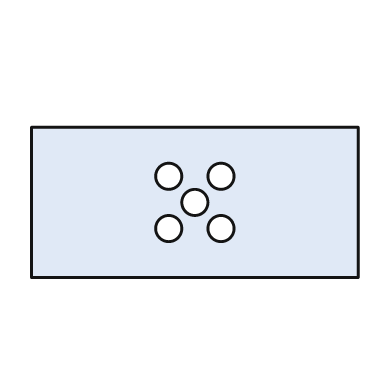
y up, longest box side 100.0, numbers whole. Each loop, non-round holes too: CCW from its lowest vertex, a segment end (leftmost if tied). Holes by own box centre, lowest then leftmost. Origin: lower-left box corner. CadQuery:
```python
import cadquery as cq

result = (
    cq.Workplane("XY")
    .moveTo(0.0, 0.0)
    .lineTo(100.0, 0.0)
    .lineTo(100.0, 46.0)
    .lineTo(0.0, 46.0)
    .close()
    .moveTo(42.0, 15.0)
    .circle(4.0)
    .moveTo(58.0, 15.0)
    .circle(4.0)
    .moveTo(50.0, 23.0)
    .circle(4.0)
    .moveTo(42.0, 31.0)
    .circle(4.0)
    .moveTo(58.0, 31.0)
    .circle(4.0)
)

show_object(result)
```